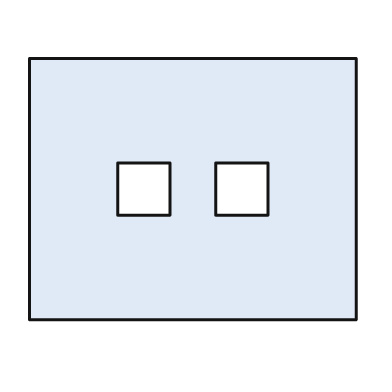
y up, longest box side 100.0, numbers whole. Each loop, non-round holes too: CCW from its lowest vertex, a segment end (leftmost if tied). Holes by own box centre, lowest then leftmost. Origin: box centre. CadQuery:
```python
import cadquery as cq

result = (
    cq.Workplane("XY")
    .moveTo(-50.0, -40.0)
    .lineTo(50.0, -40.0)
    .lineTo(50.0, 40.0)
    .lineTo(-50.0, 40.0)
    .close()
    .moveTo(-23.0, -8.0)
    .lineTo(-7.0, -8.0)
    .lineTo(-7.0, 8.0)
    .lineTo(-23.0, 8.0)
    .close()
    .moveTo(7.0, -8.0)
    .lineTo(23.0, -8.0)
    .lineTo(23.0, 8.0)
    .lineTo(7.0, 8.0)
    .close()
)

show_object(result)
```